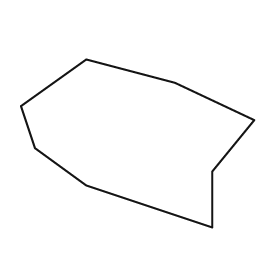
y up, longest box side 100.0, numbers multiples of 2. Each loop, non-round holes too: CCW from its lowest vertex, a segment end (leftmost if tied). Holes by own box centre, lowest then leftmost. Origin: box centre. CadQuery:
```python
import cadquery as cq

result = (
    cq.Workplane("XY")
    .moveTo(32.0, -36.0)
    .lineTo(32.0, -12.0)
    .lineTo(50.0, 10.0)
    .lineTo(16.0, 26.0)
    .lineTo(-22.0, 36.0)
    .lineTo(-50.0, 16.0)
    .lineTo(-44.0, -2.0)
    .lineTo(-22.0, -18.0)
    .close()
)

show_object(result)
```